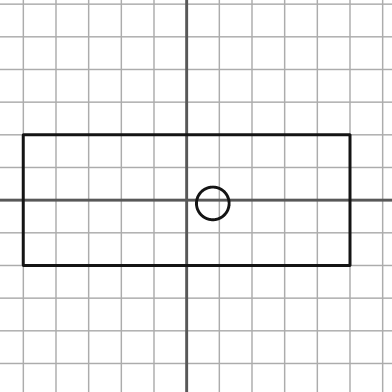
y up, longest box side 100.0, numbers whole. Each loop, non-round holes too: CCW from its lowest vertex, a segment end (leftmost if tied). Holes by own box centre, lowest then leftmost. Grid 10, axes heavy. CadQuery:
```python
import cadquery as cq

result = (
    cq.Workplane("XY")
    .moveTo(-50.0, -20.0)
    .lineTo(50.0, -20.0)
    .lineTo(50.0, 20.0)
    .lineTo(-50.0, 20.0)
    .close()
    .moveTo(8.0, -1.0)
    .circle(5.0)
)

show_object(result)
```